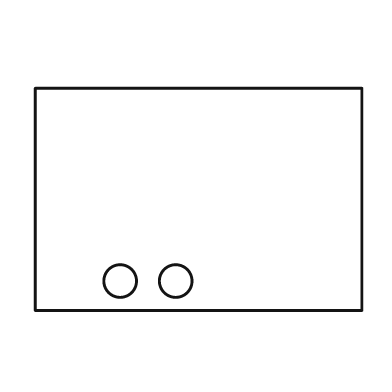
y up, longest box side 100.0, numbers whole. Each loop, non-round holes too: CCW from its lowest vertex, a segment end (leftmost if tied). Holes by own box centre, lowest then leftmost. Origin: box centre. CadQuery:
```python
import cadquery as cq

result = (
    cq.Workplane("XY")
    .moveTo(-50.0, -34.0)
    .lineTo(50.0, -34.0)
    .lineTo(50.0, 34.0)
    .lineTo(-50.0, 34.0)
    .close()
    .moveTo(-24.0, -25.0)
    .circle(5.0)
    .moveTo(-7.0, -25.0)
    .circle(5.0)
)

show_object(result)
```